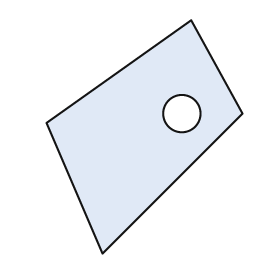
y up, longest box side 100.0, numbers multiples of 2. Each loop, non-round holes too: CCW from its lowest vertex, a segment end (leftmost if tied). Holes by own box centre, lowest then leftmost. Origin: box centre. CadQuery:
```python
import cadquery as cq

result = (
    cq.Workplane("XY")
    .moveTo(-18.0, -50.0)
    .lineTo(42.0, 10.0)
    .lineTo(20.0, 50.0)
    .lineTo(-42.0, 6.0)
    .close()
    .moveTo(16.0, 10.0)
    .circle(8.0)
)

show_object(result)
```